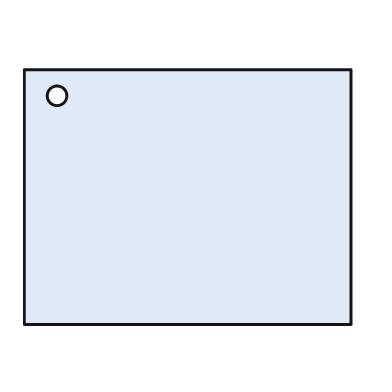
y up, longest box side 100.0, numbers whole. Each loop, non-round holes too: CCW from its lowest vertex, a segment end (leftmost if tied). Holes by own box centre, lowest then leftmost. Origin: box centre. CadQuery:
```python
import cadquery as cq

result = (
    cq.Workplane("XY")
    .moveTo(-50.0, -39.0)
    .lineTo(50.0, -39.0)
    .lineTo(50.0, 39.0)
    .lineTo(-50.0, 39.0)
    .close()
    .moveTo(-40.0, 31.0)
    .circle(3.0)
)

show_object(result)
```